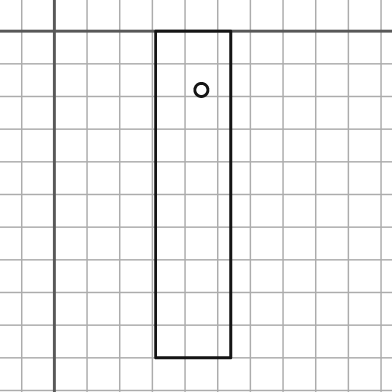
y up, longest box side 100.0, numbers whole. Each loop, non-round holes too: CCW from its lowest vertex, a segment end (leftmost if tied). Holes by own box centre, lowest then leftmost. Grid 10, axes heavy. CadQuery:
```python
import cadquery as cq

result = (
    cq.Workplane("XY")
    .moveTo(31.0, -100.0)
    .lineTo(54.0, -100.0)
    .lineTo(54.0, 0.0)
    .lineTo(31.0, 0.0)
    .close()
    .moveTo(45.0, -18.0)
    .circle(2.0)
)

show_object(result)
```